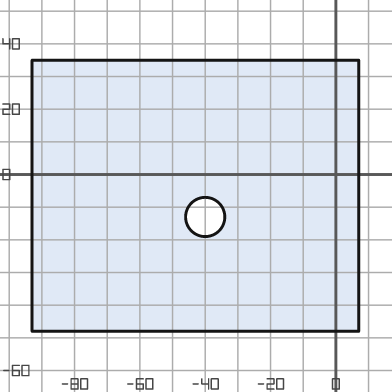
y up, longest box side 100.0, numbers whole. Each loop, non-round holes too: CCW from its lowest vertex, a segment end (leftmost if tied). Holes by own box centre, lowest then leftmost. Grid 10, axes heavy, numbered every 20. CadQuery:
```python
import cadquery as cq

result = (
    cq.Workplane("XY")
    .moveTo(-93.0, -48.0)
    .lineTo(7.0, -48.0)
    .lineTo(7.0, 35.0)
    .lineTo(-93.0, 35.0)
    .close()
    .moveTo(-40.0, -13.0)
    .circle(6.0)
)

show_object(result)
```